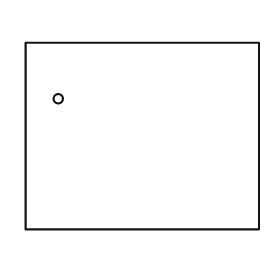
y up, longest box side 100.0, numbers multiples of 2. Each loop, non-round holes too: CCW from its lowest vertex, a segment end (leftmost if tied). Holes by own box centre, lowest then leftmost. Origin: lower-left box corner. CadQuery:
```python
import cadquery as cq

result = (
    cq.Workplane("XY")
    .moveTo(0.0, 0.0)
    .lineTo(100.0, 0.0)
    .lineTo(100.0, 80.0)
    .lineTo(0.0, 80.0)
    .close()
    .moveTo(14.0, 56.0)
    .circle(2.0)
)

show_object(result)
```